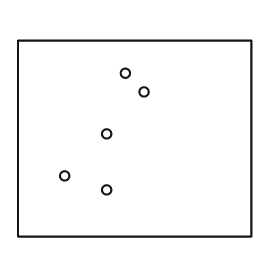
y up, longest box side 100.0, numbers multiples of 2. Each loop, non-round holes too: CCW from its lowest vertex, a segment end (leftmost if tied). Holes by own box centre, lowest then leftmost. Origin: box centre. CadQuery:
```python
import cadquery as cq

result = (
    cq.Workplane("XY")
    .moveTo(-50.0, -42.0)
    .lineTo(50.0, -42.0)
    .lineTo(50.0, 42.0)
    .lineTo(-50.0, 42.0)
    .close()
    .moveTo(-12.0, -22.0)
    .circle(2.0)
    .moveTo(-30.0, -16.0)
    .circle(2.0)
    .moveTo(-12.0, 2.0)
    .circle(2.0)
    .moveTo(4.0, 20.0)
    .circle(2.0)
    .moveTo(-4.0, 28.0)
    .circle(2.0)
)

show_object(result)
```